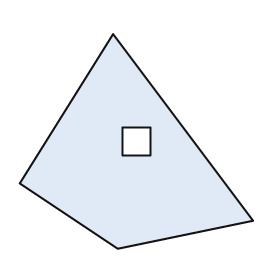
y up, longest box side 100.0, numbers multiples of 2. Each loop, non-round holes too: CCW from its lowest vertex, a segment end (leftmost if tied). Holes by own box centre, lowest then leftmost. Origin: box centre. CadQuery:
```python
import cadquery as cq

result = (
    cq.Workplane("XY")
    .moveTo(-8.0, -46.0)
    .lineTo(50.0, -34.0)
    .lineTo(-10.0, 46.0)
    .lineTo(-50.0, -18.0)
    .close()
    .moveTo(-6.0, -6.0)
    .lineTo(6.0, -6.0)
    .lineTo(6.0, 6.0)
    .lineTo(-6.0, 6.0)
    .close()
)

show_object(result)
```